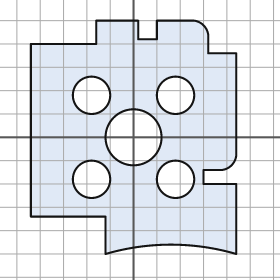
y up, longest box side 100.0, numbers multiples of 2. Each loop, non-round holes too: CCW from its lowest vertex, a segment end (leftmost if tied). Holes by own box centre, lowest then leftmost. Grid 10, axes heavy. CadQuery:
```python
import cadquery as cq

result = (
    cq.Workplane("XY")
    .moveTo(-12.0, -50.0)
    .threePointArc((16.0, -46.0), (44.0, -50.0))
    .lineTo(44.0, -20.0)
    .lineTo(30.0, -20.0)
    .lineTo(30.0, -14.0)
    .lineTo(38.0, -14.0)
    .threePointArc((42.0, -12.0), (44.0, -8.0))
    .lineTo(44.0, 36.0)
    .lineTo(32.0, 36.0)
    .lineTo(32.0, 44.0)
    .threePointArc((30.0, 48.0), (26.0, 50.0))
    .lineTo(10.0, 50.0)
    .lineTo(10.0, 42.0)
    .lineTo(2.0, 42.0)
    .lineTo(2.0, 50.0)
    .lineTo(-16.0, 50.0)
    .lineTo(-16.0, 40.0)
    .lineTo(-44.0, 40.0)
    .lineTo(-44.0, -34.0)
    .lineTo(-12.0, -34.0)
    .close()
    .moveTo(-18.0, -18.0)
    .circle(8.0)
    .moveTo(18.0, -18.0)
    .circle(8.0)
    .moveTo(0.0, 0.0)
    .circle(12.0)
    .moveTo(-18.0, 18.0)
    .circle(8.0)
    .moveTo(18.0, 18.0)
    .circle(8.0)
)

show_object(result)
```